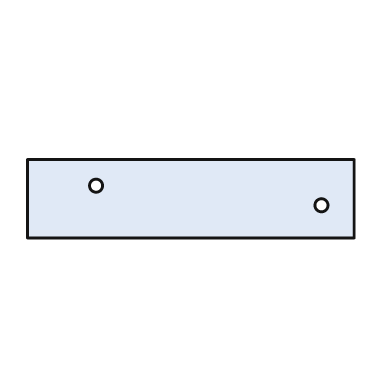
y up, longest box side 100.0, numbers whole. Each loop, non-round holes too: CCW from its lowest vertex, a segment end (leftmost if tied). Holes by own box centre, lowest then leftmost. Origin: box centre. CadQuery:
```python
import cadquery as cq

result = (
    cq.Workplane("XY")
    .moveTo(-50.0, -12.0)
    .lineTo(50.0, -12.0)
    .lineTo(50.0, 12.0)
    .lineTo(-50.0, 12.0)
    .close()
    .moveTo(40.0, -2.0)
    .circle(2.0)
    .moveTo(-29.0, 4.0)
    .circle(2.0)
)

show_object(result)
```